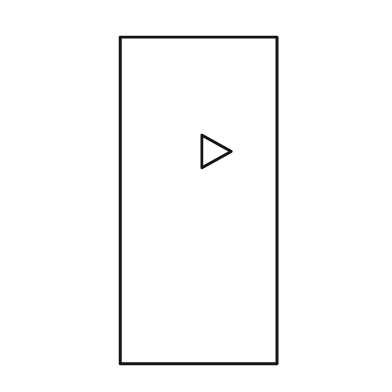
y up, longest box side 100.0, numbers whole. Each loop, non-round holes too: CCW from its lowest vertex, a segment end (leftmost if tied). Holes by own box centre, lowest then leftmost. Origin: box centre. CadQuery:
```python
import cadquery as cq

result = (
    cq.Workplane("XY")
    .moveTo(-24.0, -50.0)
    .lineTo(24.0, -50.0)
    .lineTo(24.0, 50.0)
    .lineTo(-24.0, 50.0)
    .close()
    .moveTo(1.0, 10.0)
    .lineTo(10.0, 15.0)
    .lineTo(1.0, 20.0)
    .close()
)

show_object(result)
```